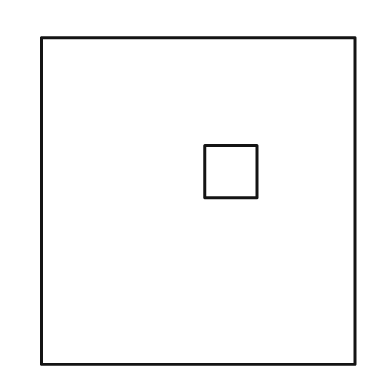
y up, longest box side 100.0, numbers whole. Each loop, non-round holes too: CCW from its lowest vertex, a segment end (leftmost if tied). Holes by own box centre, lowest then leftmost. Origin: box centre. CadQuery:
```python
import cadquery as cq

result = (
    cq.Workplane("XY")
    .moveTo(-48.0, -50.0)
    .lineTo(48.0, -50.0)
    .lineTo(48.0, 50.0)
    .lineTo(-48.0, 50.0)
    .close()
    .moveTo(2.0, 1.0)
    .lineTo(18.0, 1.0)
    .lineTo(18.0, 17.0)
    .lineTo(2.0, 17.0)
    .close()
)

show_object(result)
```